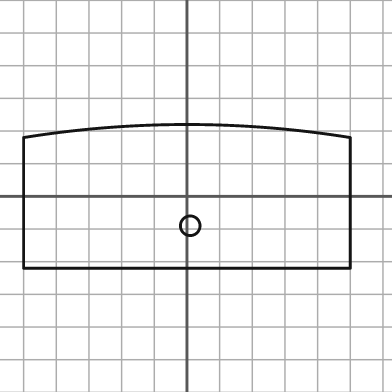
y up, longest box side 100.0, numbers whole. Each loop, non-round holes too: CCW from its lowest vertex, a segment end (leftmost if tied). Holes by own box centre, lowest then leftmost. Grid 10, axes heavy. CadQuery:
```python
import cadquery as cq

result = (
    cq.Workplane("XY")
    .moveTo(-50.0, -22.0)
    .lineTo(50.0, -22.0)
    .lineTo(50.0, 18.0)
    .threePointArc((0.0, 22.0), (-50.0, 18.0))
    .close()
    .moveTo(1.0, -9.0)
    .circle(3.0)
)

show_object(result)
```